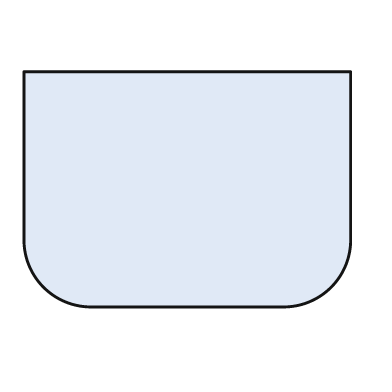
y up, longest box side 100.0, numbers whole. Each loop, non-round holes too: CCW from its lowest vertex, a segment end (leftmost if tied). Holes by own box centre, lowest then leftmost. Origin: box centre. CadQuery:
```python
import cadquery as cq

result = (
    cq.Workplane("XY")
    .moveTo(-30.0, -36.0)
    .lineTo(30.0, -36.0)
    .threePointArc((44.0, -30.0), (50.0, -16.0))
    .lineTo(50.0, 36.0)
    .lineTo(-50.0, 36.0)
    .lineTo(-50.0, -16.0)
    .threePointArc((-44.0, -30.0), (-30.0, -36.0))
    .close()
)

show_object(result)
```